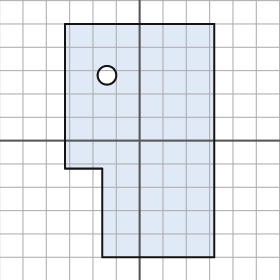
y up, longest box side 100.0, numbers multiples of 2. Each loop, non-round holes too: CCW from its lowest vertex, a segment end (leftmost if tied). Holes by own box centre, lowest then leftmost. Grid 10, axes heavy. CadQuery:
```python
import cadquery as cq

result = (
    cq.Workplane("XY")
    .moveTo(-16.0, -50.0)
    .lineTo(32.0, -50.0)
    .lineTo(32.0, 50.0)
    .lineTo(-32.0, 50.0)
    .lineTo(-32.0, -12.0)
    .lineTo(-16.0, -12.0)
    .close()
    .moveTo(-14.0, 28.0)
    .circle(4.0)
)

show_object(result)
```